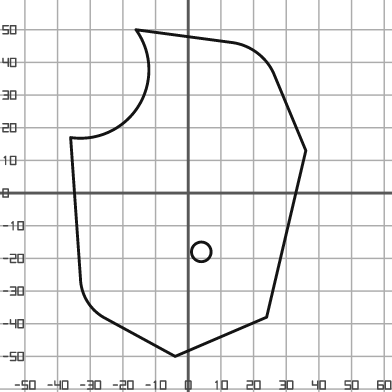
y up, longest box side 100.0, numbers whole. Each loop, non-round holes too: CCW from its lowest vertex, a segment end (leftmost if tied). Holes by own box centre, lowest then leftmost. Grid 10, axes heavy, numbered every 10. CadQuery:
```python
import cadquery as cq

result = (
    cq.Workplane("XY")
    .moveTo(-4.0, -50.0)
    .lineTo(24.0, -38.0)
    .lineTo(36.0, 13.0)
    .lineTo(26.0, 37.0)
    .threePointArc((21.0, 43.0), (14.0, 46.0))
    .lineTo(-16.0, 50.0)
    .threePointArc((-15.0, 27.0), (-36.0, 17.0))
    .lineTo(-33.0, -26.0)
    .threePointArc((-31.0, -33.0), (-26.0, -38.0))
    .close()
    .moveTo(4.0, -18.0)
    .circle(3.0)
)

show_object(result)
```